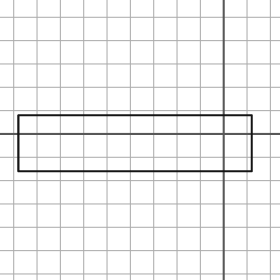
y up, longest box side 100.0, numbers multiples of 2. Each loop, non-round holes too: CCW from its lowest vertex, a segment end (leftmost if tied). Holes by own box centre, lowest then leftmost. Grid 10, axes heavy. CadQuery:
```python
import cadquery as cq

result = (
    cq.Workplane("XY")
    .moveTo(-88.0, -16.0)
    .lineTo(12.0, -16.0)
    .lineTo(12.0, 8.0)
    .lineTo(-88.0, 8.0)
    .close()
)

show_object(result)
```